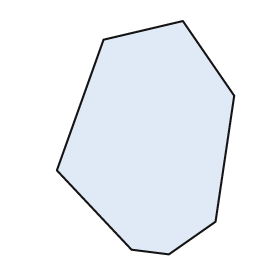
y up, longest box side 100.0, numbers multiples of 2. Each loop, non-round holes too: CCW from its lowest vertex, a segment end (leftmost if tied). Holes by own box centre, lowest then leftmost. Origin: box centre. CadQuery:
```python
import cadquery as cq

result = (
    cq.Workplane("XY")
    .moveTo(10.0, -50.0)
    .lineTo(30.0, -36.0)
    .lineTo(38.0, 18.0)
    .lineTo(16.0, 50.0)
    .lineTo(-18.0, 42.0)
    .lineTo(-38.0, -14.0)
    .lineTo(-6.0, -48.0)
    .close()
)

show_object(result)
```